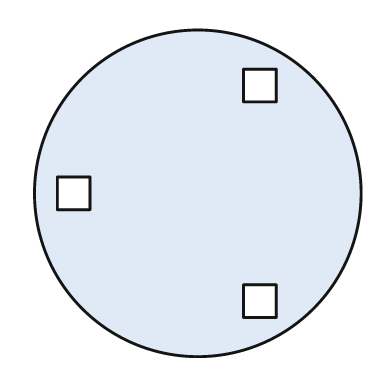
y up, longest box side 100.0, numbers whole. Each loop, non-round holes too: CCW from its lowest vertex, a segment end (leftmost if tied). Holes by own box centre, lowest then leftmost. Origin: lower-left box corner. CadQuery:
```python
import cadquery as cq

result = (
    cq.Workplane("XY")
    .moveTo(50.0, 50.0)
    .circle(50.0)
    .moveTo(64.0, 12.0)
    .lineTo(74.0, 12.0)
    .lineTo(74.0, 22.0)
    .lineTo(64.0, 22.0)
    .close()
    .moveTo(7.0, 45.0)
    .lineTo(17.0, 45.0)
    .lineTo(17.0, 55.0)
    .lineTo(7.0, 55.0)
    .close()
    .moveTo(64.0, 78.0)
    .lineTo(74.0, 78.0)
    .lineTo(74.0, 88.0)
    .lineTo(64.0, 88.0)
    .close()
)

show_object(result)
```